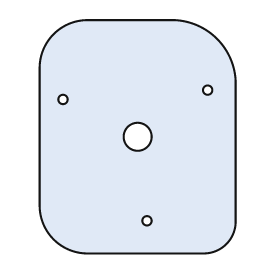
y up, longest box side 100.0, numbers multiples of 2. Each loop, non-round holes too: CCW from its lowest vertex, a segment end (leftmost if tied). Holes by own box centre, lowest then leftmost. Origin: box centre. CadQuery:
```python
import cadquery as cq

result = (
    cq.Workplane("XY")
    .moveTo(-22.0, -50.0)
    .lineTo(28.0, -50.0)
    .threePointArc((38.0, -46.0), (42.0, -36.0))
    .lineTo(42.0, 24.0)
    .threePointArc((34.0, 42.0), (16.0, 50.0))
    .lineTo(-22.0, 50.0)
    .threePointArc((-36.0, 44.0), (-42.0, 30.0))
    .lineTo(-42.0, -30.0)
    .threePointArc((-36.0, -44.0), (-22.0, -50.0))
    .close()
    .moveTo(4.0, -36.0)
    .circle(2.0)
    .moveTo(0.0, 0.0)
    .circle(6.0)
    .moveTo(-32.0, 16.0)
    .circle(2.0)
    .moveTo(30.0, 20.0)
    .circle(2.0)
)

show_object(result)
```